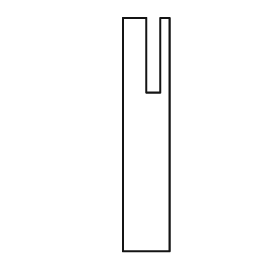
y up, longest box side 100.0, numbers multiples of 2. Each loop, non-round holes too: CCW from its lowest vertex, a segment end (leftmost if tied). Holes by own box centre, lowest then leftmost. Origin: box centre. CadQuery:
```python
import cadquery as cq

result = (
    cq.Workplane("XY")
    .moveTo(-10.0, -50.0)
    .lineTo(10.0, -50.0)
    .lineTo(10.0, 50.0)
    .lineTo(6.0, 50.0)
    .lineTo(6.0, 18.0)
    .lineTo(0.0, 18.0)
    .lineTo(0.0, 50.0)
    .lineTo(-10.0, 50.0)
    .close()
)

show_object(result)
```